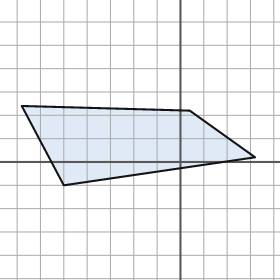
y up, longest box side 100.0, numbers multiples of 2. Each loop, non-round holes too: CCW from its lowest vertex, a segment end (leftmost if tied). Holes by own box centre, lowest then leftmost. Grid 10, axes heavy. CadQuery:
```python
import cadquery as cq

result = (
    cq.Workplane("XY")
    .moveTo(-50.0, -10.0)
    .lineTo(32.0, 2.0)
    .lineTo(4.0, 22.0)
    .lineTo(-68.0, 24.0)
    .close()
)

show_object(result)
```